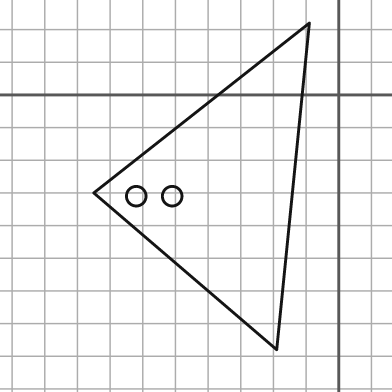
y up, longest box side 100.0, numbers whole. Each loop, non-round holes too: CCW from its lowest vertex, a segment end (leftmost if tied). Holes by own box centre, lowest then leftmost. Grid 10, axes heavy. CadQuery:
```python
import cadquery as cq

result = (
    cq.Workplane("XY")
    .moveTo(-19.0, -78.0)
    .lineTo(-9.0, 22.0)
    .lineTo(-75.0, -30.0)
    .close()
    .moveTo(-62.0, -31.0)
    .circle(3.0)
    .moveTo(-51.0, -31.0)
    .circle(3.0)
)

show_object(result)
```